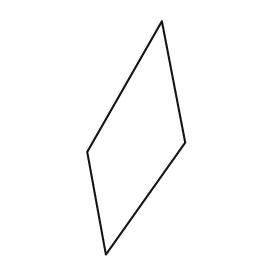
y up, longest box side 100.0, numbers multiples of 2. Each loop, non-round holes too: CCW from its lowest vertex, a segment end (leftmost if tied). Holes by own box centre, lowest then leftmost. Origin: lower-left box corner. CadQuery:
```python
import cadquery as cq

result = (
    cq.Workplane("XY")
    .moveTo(8.0, 0.0)
    .lineTo(42.0, 48.0)
    .lineTo(32.0, 100.0)
    .lineTo(0.0, 44.0)
    .close()
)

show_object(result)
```